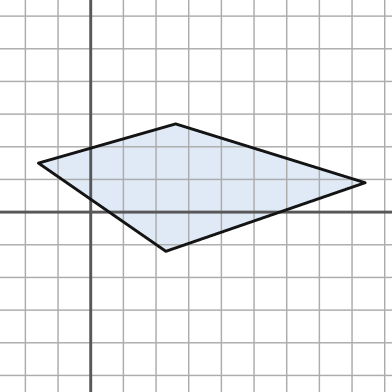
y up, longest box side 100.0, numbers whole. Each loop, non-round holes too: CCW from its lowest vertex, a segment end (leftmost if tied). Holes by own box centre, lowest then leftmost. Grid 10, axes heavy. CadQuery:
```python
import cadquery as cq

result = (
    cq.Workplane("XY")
    .moveTo(23.0, -12.0)
    .lineTo(84.0, 9.0)
    .lineTo(26.0, 27.0)
    .lineTo(-16.0, 15.0)
    .close()
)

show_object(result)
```